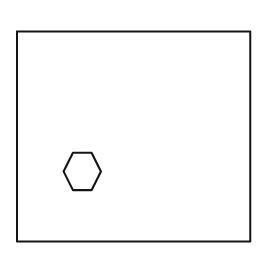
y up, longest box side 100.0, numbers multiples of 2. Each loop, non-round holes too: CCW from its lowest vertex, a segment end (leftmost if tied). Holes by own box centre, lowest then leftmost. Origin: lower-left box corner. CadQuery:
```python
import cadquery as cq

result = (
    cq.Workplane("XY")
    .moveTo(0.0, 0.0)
    .lineTo(100.0, 0.0)
    .lineTo(100.0, 90.0)
    .lineTo(0.0, 90.0)
    .close()
    .moveTo(24.0, 22.0)
    .lineTo(32.0, 22.0)
    .lineTo(36.0, 30.0)
    .lineTo(32.0, 38.0)
    .lineTo(24.0, 38.0)
    .lineTo(20.0, 30.0)
    .close()
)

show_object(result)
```